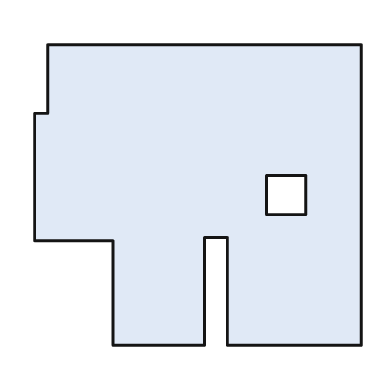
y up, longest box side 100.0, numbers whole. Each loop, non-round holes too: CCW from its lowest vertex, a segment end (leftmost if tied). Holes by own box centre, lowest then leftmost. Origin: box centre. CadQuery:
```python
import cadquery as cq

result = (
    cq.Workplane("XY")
    .moveTo(-26.0, -46.0)
    .lineTo(2.0, -46.0)
    .lineTo(2.0, -13.0)
    .lineTo(9.0, -13.0)
    .lineTo(9.0, -46.0)
    .lineTo(50.0, -46.0)
    .lineTo(50.0, 46.0)
    .lineTo(-46.0, 46.0)
    .lineTo(-46.0, 25.0)
    .lineTo(-50.0, 25.0)
    .lineTo(-50.0, -14.0)
    .lineTo(-26.0, -14.0)
    .close()
    .moveTo(21.0, -6.0)
    .lineTo(33.0, -6.0)
    .lineTo(33.0, 6.0)
    .lineTo(21.0, 6.0)
    .close()
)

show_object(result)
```